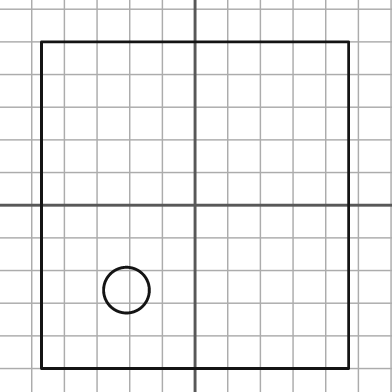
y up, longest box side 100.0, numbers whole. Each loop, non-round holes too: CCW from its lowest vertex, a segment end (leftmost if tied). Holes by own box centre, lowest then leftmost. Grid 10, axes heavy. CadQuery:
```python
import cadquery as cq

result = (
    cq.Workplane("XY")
    .moveTo(-47.0, -50.0)
    .lineTo(47.0, -50.0)
    .lineTo(47.0, 50.0)
    .lineTo(-47.0, 50.0)
    .close()
    .moveTo(-21.0, -26.0)
    .circle(7.0)
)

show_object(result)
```